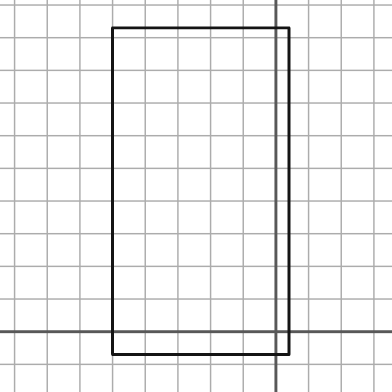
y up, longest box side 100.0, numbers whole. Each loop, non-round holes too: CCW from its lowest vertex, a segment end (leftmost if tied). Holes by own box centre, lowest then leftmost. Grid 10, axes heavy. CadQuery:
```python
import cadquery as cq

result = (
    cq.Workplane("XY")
    .moveTo(-50.0, -7.0)
    .lineTo(4.0, -7.0)
    .lineTo(4.0, 93.0)
    .lineTo(-50.0, 93.0)
    .close()
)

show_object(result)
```